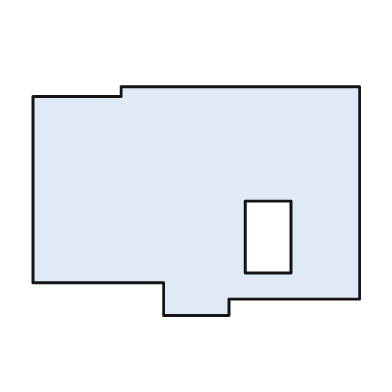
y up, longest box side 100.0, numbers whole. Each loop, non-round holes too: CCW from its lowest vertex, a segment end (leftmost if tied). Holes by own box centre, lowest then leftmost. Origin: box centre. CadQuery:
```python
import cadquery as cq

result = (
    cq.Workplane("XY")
    .moveTo(-10.0, -35.0)
    .lineTo(10.0, -35.0)
    .lineTo(10.0, -30.0)
    .lineTo(50.0, -30.0)
    .lineTo(50.0, 35.0)
    .lineTo(-23.0, 35.0)
    .lineTo(-23.0, 32.0)
    .lineTo(-50.0, 32.0)
    .lineTo(-50.0, -25.0)
    .lineTo(-10.0, -25.0)
    .close()
    .moveTo(15.0, -22.0)
    .lineTo(29.0, -22.0)
    .lineTo(29.0, 0.0)
    .lineTo(15.0, 0.0)
    .close()
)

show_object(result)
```